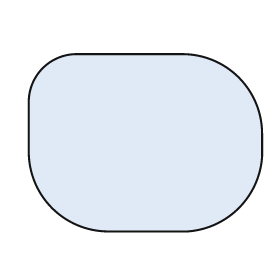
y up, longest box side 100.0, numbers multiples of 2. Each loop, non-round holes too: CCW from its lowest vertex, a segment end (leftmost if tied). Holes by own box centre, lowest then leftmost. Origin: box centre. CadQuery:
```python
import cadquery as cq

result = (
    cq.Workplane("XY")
    .moveTo(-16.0, -38.0)
    .lineTo(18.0, -38.0)
    .threePointArc((40.0, -28.0), (50.0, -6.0))
    .lineTo(50.0, 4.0)
    .threePointArc((40.0, 28.0), (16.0, 38.0))
    .lineTo(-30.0, 38.0)
    .threePointArc((-44.0, 32.0), (-50.0, 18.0))
    .lineTo(-50.0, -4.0)
    .threePointArc((-40.0, -28.0), (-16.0, -38.0))
    .close()
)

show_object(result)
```